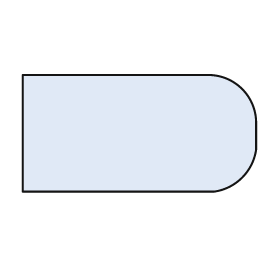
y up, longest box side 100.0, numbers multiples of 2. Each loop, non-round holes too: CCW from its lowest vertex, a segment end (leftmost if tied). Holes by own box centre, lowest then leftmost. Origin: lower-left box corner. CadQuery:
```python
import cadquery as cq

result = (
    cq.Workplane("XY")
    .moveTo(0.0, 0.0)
    .lineTo(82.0, 0.0)
    .threePointArc((94.0, 6.0), (100.0, 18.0))
    .lineTo(100.0, 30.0)
    .threePointArc((94.0, 44.0), (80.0, 50.0))
    .lineTo(0.0, 50.0)
    .close()
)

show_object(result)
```